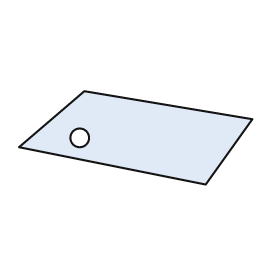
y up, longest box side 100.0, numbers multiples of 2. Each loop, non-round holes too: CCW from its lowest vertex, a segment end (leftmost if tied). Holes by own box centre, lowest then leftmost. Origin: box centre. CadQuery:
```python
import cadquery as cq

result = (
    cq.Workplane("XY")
    .moveTo(30.0, -20.0)
    .lineTo(50.0, 8.0)
    .lineTo(-22.0, 20.0)
    .lineTo(-50.0, -4.0)
    .close()
    .moveTo(-24.0, 0.0)
    .circle(4.0)
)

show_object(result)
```